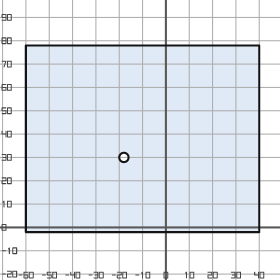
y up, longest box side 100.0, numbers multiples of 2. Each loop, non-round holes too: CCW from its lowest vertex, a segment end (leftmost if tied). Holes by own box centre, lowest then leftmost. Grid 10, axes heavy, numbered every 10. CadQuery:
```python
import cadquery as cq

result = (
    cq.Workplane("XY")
    .moveTo(-60.0, -2.0)
    .lineTo(40.0, -2.0)
    .lineTo(40.0, 78.0)
    .lineTo(-60.0, 78.0)
    .close()
    .moveTo(-18.0, 30.0)
    .circle(2.0)
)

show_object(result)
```